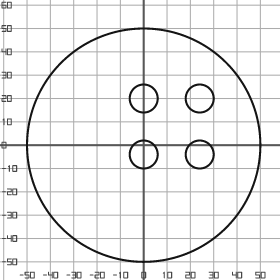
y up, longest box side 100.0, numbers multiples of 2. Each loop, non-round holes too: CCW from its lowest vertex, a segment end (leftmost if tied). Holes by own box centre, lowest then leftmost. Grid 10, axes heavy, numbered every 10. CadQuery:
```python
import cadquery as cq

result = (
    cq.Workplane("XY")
    .moveTo(0.0, 0.0)
    .circle(50.0)
    .moveTo(0.0, -4.0)
    .circle(6.0)
    .moveTo(24.0, -4.0)
    .circle(6.0)
    .moveTo(0.0, 20.0)
    .circle(6.0)
    .moveTo(24.0, 20.0)
    .circle(6.0)
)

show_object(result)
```